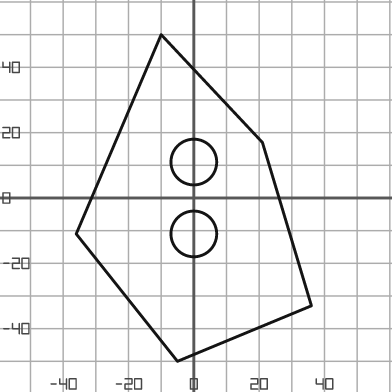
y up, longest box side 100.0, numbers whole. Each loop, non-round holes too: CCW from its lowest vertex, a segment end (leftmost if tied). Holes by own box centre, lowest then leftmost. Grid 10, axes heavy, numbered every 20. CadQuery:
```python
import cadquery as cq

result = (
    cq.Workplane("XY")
    .moveTo(-5.0, -50.0)
    .lineTo(36.0, -33.0)
    .lineTo(21.0, 17.0)
    .lineTo(-10.0, 50.0)
    .lineTo(-36.0, -11.0)
    .close()
    .moveTo(0.0, -11.0)
    .circle(7.0)
    .moveTo(0.0, 11.0)
    .circle(7.0)
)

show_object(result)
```